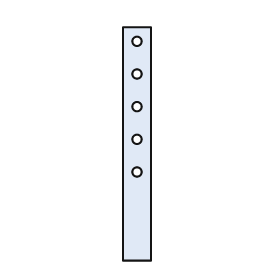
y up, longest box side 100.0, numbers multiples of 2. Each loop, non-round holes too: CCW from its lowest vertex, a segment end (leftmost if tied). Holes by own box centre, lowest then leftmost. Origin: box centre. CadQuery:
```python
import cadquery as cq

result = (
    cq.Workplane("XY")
    .moveTo(-6.0, -50.0)
    .lineTo(6.0, -50.0)
    .lineTo(6.0, 50.0)
    .lineTo(-6.0, 50.0)
    .close()
    .moveTo(0.0, -12.0)
    .circle(2.0)
    .moveTo(0.0, 2.0)
    .circle(2.0)
    .moveTo(0.0, 16.0)
    .circle(2.0)
    .moveTo(0.0, 30.0)
    .circle(2.0)
    .moveTo(0.0, 44.0)
    .circle(2.0)
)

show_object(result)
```